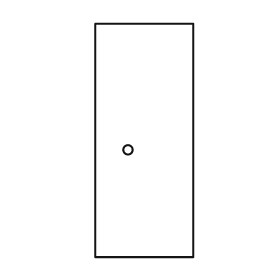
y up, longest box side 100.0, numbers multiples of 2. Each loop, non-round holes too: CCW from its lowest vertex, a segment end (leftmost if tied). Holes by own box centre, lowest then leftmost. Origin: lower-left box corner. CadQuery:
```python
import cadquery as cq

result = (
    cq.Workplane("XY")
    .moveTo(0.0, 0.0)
    .lineTo(42.0, 0.0)
    .lineTo(42.0, 100.0)
    .lineTo(0.0, 100.0)
    .close()
    .moveTo(14.0, 46.0)
    .circle(2.0)
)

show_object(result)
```